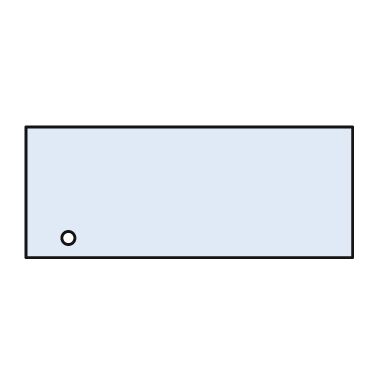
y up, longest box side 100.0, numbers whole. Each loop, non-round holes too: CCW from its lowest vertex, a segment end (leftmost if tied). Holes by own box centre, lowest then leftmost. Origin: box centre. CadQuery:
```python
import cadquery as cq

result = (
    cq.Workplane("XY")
    .moveTo(-50.0, -20.0)
    .lineTo(50.0, -20.0)
    .lineTo(50.0, 20.0)
    .lineTo(-50.0, 20.0)
    .close()
    .moveTo(-37.0, -14.0)
    .circle(2.0)
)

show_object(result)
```